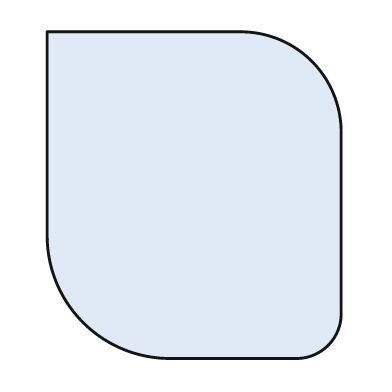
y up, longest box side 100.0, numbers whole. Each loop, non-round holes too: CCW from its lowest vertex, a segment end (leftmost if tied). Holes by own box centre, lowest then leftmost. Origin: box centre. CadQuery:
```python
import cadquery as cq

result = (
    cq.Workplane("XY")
    .moveTo(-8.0, -50.0)
    .lineTo(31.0, -50.0)
    .threePointArc((41.0, -46.0), (45.0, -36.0))
    .lineTo(45.0, 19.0)
    .threePointArc((36.0, 41.0), (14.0, 50.0))
    .lineTo(-45.0, 50.0)
    .lineTo(-45.0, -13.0)
    .threePointArc((-34.0, -39.0), (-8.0, -50.0))
    .close()
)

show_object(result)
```